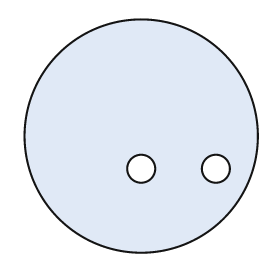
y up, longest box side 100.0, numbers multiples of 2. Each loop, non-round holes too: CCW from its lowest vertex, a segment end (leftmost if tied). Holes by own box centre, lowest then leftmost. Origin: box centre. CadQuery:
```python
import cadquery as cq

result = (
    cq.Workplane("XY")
    .moveTo(0.0, 0.0)
    .circle(50.0)
    .moveTo(0.0, -14.0)
    .circle(6.0)
    .moveTo(32.0, -14.0)
    .circle(6.0)
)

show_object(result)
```